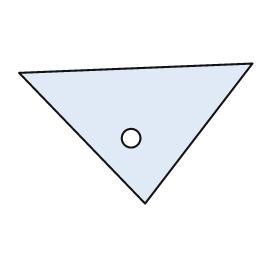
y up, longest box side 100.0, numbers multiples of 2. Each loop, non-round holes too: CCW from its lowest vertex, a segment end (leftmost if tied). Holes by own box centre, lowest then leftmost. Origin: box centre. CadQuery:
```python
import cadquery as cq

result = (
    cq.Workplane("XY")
    .moveTo(4.0, -30.0)
    .lineTo(50.0, 30.0)
    .lineTo(-50.0, 26.0)
    .close()
    .moveTo(-2.0, -2.0)
    .circle(4.0)
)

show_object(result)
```